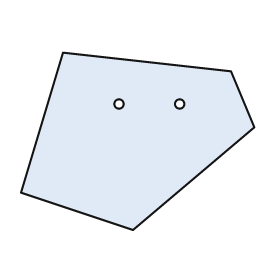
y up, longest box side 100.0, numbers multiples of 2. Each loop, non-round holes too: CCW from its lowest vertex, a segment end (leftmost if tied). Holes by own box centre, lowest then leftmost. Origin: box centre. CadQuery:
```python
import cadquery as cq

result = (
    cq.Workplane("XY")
    .moveTo(-2.0, -38.0)
    .lineTo(50.0, 6.0)
    .lineTo(40.0, 30.0)
    .lineTo(-32.0, 38.0)
    .lineTo(-50.0, -22.0)
    .close()
    .moveTo(-8.0, 16.0)
    .circle(2.0)
    .moveTo(18.0, 16.0)
    .circle(2.0)
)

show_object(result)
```